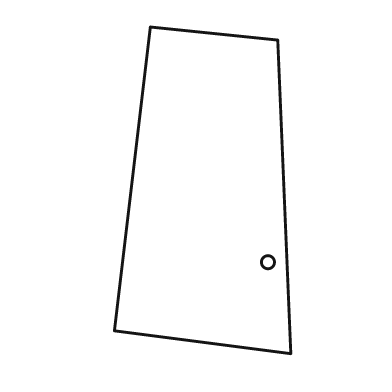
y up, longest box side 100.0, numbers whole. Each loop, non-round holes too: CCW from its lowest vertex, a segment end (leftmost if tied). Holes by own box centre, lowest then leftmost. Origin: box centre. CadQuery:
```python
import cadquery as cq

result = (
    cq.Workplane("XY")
    .moveTo(27.0, -50.0)
    .lineTo(23.0, 46.0)
    .lineTo(-16.0, 50.0)
    .lineTo(-27.0, -43.0)
    .close()
    .moveTo(20.0, -22.0)
    .circle(2.0)
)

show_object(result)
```